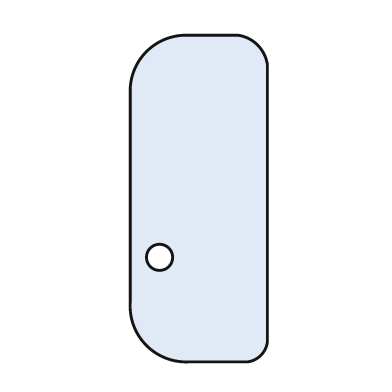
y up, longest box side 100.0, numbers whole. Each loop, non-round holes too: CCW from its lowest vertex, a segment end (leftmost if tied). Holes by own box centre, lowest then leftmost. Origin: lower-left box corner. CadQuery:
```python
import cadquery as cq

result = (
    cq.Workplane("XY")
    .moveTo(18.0, 0.0)
    .lineTo(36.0, 0.0)
    .threePointArc((40.0, 2.0), (42.0, 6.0))
    .lineTo(42.0, 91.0)
    .threePointArc((39.0, 97.0), (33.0, 100.0))
    .lineTo(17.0, 100.0)
    .threePointArc((5.0, 95.0), (0.0, 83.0))
    .lineTo(0.0, 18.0)
    .threePointArc((5.0, 5.0), (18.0, 0.0))
    .close()
    .moveTo(9.0, 32.0)
    .circle(4.0)
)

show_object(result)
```